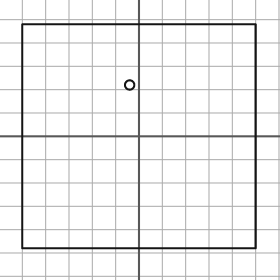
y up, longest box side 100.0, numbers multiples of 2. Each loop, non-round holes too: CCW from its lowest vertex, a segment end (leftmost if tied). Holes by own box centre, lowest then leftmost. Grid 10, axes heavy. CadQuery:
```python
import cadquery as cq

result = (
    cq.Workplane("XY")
    .moveTo(-50.0, -48.0)
    .lineTo(50.0, -48.0)
    .lineTo(50.0, 48.0)
    .lineTo(-50.0, 48.0)
    .close()
    .moveTo(-4.0, 22.0)
    .circle(2.0)
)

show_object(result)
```